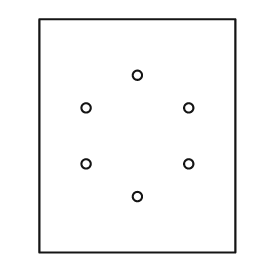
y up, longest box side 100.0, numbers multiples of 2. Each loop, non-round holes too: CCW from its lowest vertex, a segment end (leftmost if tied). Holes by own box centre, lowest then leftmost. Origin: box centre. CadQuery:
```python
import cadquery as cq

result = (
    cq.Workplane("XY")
    .moveTo(-42.0, -50.0)
    .lineTo(42.0, -50.0)
    .lineTo(42.0, 50.0)
    .lineTo(-42.0, 50.0)
    .close()
    .moveTo(0.0, -26.0)
    .circle(2.0)
    .moveTo(-22.0, -12.0)
    .circle(2.0)
    .moveTo(22.0, -12.0)
    .circle(2.0)
    .moveTo(-22.0, 12.0)
    .circle(2.0)
    .moveTo(22.0, 12.0)
    .circle(2.0)
    .moveTo(0.0, 26.0)
    .circle(2.0)
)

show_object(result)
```